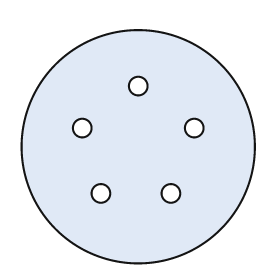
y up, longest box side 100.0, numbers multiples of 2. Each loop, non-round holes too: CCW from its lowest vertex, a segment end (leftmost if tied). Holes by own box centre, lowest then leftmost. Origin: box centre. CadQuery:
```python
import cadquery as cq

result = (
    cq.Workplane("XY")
    .moveTo(0.0, 0.0)
    .circle(50.0)
    .moveTo(-16.0, -20.0)
    .circle(4.0)
    .moveTo(14.0, -20.0)
    .circle(4.0)
    .moveTo(-24.0, 8.0)
    .circle(4.0)
    .moveTo(24.0, 8.0)
    .circle(4.0)
    .moveTo(0.0, 26.0)
    .circle(4.0)
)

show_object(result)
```